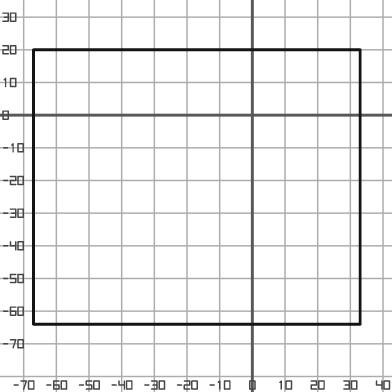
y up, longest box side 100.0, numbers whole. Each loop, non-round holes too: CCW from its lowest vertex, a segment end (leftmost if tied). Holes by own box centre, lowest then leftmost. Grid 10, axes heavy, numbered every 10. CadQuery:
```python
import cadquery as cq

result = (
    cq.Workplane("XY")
    .moveTo(-67.0, -64.0)
    .lineTo(33.0, -64.0)
    .lineTo(33.0, 20.0)
    .lineTo(-67.0, 20.0)
    .close()
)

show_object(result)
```